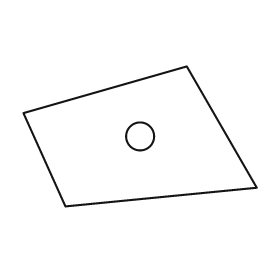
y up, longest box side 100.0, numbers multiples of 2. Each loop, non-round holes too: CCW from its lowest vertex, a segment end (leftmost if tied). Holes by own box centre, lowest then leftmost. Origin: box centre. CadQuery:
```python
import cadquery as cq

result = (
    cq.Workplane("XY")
    .moveTo(-32.0, -30.0)
    .lineTo(50.0, -22.0)
    .lineTo(20.0, 30.0)
    .lineTo(-50.0, 10.0)
    .close()
    .moveTo(0.0, 0.0)
    .circle(6.0)
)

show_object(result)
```